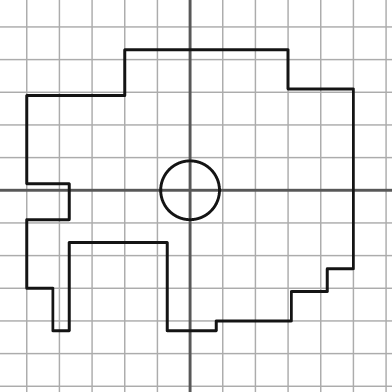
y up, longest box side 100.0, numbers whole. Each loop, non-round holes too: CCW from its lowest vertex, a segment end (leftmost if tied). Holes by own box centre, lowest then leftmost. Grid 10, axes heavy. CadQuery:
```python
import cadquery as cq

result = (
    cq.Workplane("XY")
    .moveTo(-42.0, -43.0)
    .lineTo(-37.0, -43.0)
    .lineTo(-37.0, -16.0)
    .lineTo(-7.0, -16.0)
    .lineTo(-7.0, -43.0)
    .lineTo(8.0, -43.0)
    .lineTo(8.0, -40.0)
    .lineTo(31.0, -40.0)
    .lineTo(31.0, -31.0)
    .lineTo(42.0, -31.0)
    .lineTo(42.0, -24.0)
    .lineTo(50.0, -24.0)
    .lineTo(50.0, 31.0)
    .lineTo(30.0, 31.0)
    .lineTo(30.0, 43.0)
    .lineTo(-20.0, 43.0)
    .lineTo(-20.0, 29.0)
    .lineTo(-50.0, 29.0)
    .lineTo(-50.0, 2.0)
    .lineTo(-37.0, 2.0)
    .lineTo(-37.0, -9.0)
    .lineTo(-50.0, -9.0)
    .lineTo(-50.0, -30.0)
    .lineTo(-42.0, -30.0)
    .close()
    .moveTo(0.0, 0.0)
    .circle(9.0)
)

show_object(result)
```